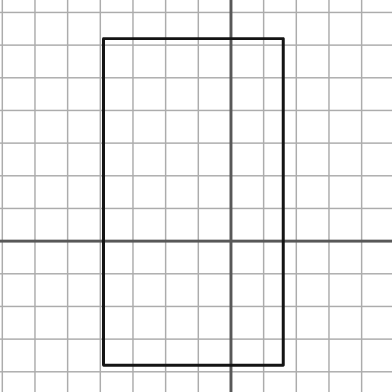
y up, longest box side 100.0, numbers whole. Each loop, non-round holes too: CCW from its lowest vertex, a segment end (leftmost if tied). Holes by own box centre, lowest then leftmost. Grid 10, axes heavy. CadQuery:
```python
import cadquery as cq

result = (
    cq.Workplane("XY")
    .moveTo(-39.0, -38.0)
    .lineTo(16.0, -38.0)
    .lineTo(16.0, 62.0)
    .lineTo(-39.0, 62.0)
    .close()
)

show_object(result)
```